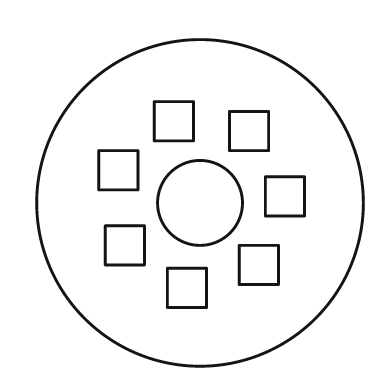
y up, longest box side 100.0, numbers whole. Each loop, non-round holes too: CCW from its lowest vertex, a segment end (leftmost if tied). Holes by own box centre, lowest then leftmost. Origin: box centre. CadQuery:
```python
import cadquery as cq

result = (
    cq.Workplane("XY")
    .moveTo(0.0, 0.0)
    .circle(50.0)
    .moveTo(-10.0, -32.0)
    .lineTo(2.0, -32.0)
    .lineTo(2.0, -20.0)
    .lineTo(-10.0, -20.0)
    .close()
    .moveTo(12.0, -25.0)
    .lineTo(24.0, -25.0)
    .lineTo(24.0, -13.0)
    .lineTo(12.0, -13.0)
    .close()
    .moveTo(-29.0, -19.0)
    .lineTo(-17.0, -19.0)
    .lineTo(-17.0, -7.0)
    .lineTo(-29.0, -7.0)
    .close()
    .moveTo(0.0, 0.0)
    .circle(13.0)
    .moveTo(20.0, -4.0)
    .lineTo(32.0, -4.0)
    .lineTo(32.0, 8.0)
    .lineTo(20.0, 8.0)
    .close()
    .moveTo(-31.0, 4.0)
    .lineTo(-19.0, 4.0)
    .lineTo(-19.0, 16.0)
    .lineTo(-31.0, 16.0)
    .close()
    .moveTo(9.0, 16.0)
    .lineTo(21.0, 16.0)
    .lineTo(21.0, 28.0)
    .lineTo(9.0, 28.0)
    .close()
    .moveTo(-14.0, 19.0)
    .lineTo(-2.0, 19.0)
    .lineTo(-2.0, 31.0)
    .lineTo(-14.0, 31.0)
    .close()
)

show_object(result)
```